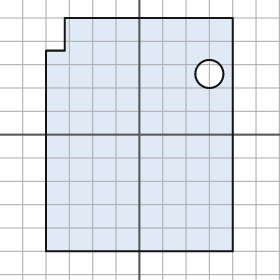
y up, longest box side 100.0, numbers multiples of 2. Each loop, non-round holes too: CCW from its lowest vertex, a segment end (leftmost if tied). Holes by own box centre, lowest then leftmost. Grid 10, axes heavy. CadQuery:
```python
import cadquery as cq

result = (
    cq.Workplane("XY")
    .moveTo(-40.0, -50.0)
    .lineTo(40.0, -50.0)
    .lineTo(40.0, 50.0)
    .lineTo(-32.0, 50.0)
    .lineTo(-32.0, 36.0)
    .lineTo(-40.0, 36.0)
    .close()
    .moveTo(30.0, 26.0)
    .circle(6.0)
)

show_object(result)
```